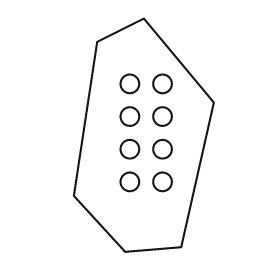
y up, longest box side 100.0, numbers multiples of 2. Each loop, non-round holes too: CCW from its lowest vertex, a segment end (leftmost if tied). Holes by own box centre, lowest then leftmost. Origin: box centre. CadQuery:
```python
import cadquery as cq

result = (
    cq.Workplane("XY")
    .moveTo(-8.0, -50.0)
    .lineTo(16.0, -48.0)
    .lineTo(30.0, 14.0)
    .lineTo(0.0, 50.0)
    .lineTo(-20.0, 40.0)
    .lineTo(-30.0, -26.0)
    .close()
    .moveTo(-6.0, -20.0)
    .circle(4.0)
    .moveTo(8.0, -20.0)
    .circle(4.0)
    .moveTo(-6.0, -6.0)
    .circle(4.0)
    .moveTo(8.0, -6.0)
    .circle(4.0)
    .moveTo(-6.0, 8.0)
    .circle(4.0)
    .moveTo(8.0, 8.0)
    .circle(4.0)
    .moveTo(-6.0, 22.0)
    .circle(4.0)
    .moveTo(8.0, 22.0)
    .circle(4.0)
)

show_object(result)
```